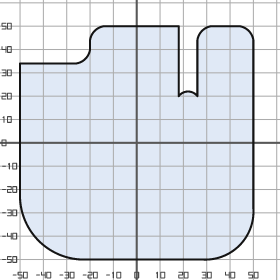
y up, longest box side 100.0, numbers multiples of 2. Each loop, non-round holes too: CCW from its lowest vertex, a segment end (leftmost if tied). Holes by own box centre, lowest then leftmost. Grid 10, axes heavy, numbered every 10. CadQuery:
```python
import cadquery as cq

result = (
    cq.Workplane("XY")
    .moveTo(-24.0, -50.0)
    .lineTo(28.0, -50.0)
    .threePointArc((44.0, -44.0), (50.0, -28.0))
    .lineTo(50.0, 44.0)
    .threePointArc((48.0, 48.0), (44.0, 50.0))
    .lineTo(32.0, 50.0)
    .threePointArc((28.0, 48.0), (26.0, 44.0))
    .lineTo(26.0, 20.0)
    .threePointArc((22.0, 22.0), (18.0, 20.0))
    .lineTo(18.0, 50.0)
    .lineTo(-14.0, 50.0)
    .threePointArc((-18.0, 48.0), (-20.0, 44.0))
    .lineTo(-20.0, 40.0)
    .threePointArc((-22.0, 36.0), (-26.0, 34.0))
    .lineTo(-50.0, 34.0)
    .lineTo(-50.0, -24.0)
    .threePointArc((-42.0, -42.0), (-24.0, -50.0))
    .close()
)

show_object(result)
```